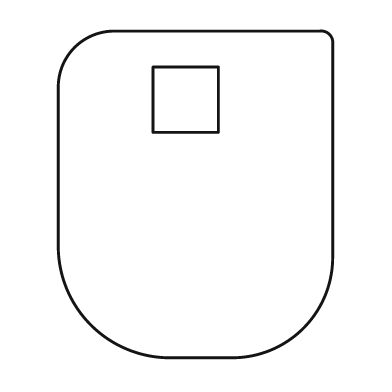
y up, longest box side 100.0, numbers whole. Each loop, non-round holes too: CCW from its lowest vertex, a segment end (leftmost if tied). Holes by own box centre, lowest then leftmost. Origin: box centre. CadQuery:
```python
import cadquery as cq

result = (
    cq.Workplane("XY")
    .moveTo(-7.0, -50.0)
    .lineTo(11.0, -50.0)
    .threePointArc((33.0, -41.0), (42.0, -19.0))
    .lineTo(42.0, 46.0)
    .threePointArc((41.0, 49.0), (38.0, 50.0))
    .lineTo(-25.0, 50.0)
    .threePointArc((-37.0, 45.0), (-42.0, 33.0))
    .lineTo(-42.0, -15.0)
    .threePointArc((-32.0, -40.0), (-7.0, -50.0))
    .close()
    .moveTo(-13.0, 19.0)
    .lineTo(7.0, 19.0)
    .lineTo(7.0, 39.0)
    .lineTo(-13.0, 39.0)
    .close()
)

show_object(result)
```